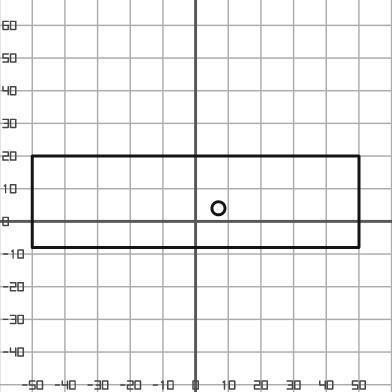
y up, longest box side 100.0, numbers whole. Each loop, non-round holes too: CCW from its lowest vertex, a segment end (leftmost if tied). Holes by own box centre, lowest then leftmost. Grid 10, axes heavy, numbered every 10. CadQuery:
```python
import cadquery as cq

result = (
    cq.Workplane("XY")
    .moveTo(-50.0, -8.0)
    .lineTo(50.0, -8.0)
    .lineTo(50.0, 20.0)
    .lineTo(-50.0, 20.0)
    .close()
    .moveTo(7.0, 4.0)
    .circle(2.0)
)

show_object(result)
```